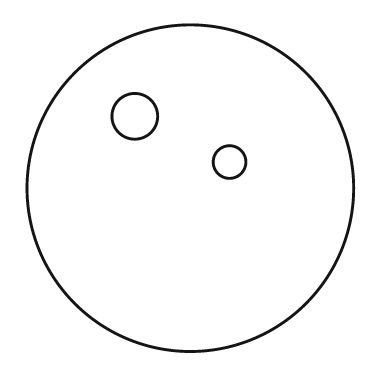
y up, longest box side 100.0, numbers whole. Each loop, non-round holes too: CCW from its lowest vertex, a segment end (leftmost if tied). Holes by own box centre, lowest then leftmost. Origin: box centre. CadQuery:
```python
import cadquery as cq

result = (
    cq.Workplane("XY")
    .moveTo(0.0, 0.0)
    .circle(50.0)
    .moveTo(12.0, 8.0)
    .circle(5.0)
    .moveTo(-17.0, 22.0)
    .circle(7.0)
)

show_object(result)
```